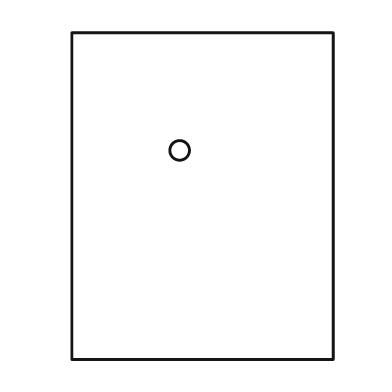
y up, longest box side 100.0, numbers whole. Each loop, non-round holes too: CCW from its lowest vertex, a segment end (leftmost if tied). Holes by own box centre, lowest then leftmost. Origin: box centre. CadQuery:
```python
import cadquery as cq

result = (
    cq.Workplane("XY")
    .moveTo(-40.0, -50.0)
    .lineTo(40.0, -50.0)
    .lineTo(40.0, 50.0)
    .lineTo(-40.0, 50.0)
    .close()
    .moveTo(-7.0, 14.0)
    .circle(3.0)
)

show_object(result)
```